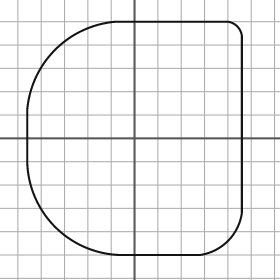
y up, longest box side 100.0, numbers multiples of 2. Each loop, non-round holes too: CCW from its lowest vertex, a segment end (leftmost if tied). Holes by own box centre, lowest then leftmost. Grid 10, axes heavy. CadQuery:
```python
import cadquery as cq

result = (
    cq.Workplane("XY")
    .moveTo(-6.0, -50.0)
    .lineTo(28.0, -50.0)
    .threePointArc((40.0, -44.0), (46.0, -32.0))
    .lineTo(46.0, 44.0)
    .threePointArc((44.0, 48.0), (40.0, 50.0))
    .lineTo(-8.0, 50.0)
    .threePointArc((-34.0, 38.0), (-46.0, 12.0))
    .lineTo(-46.0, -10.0)
    .threePointArc((-34.0, -38.0), (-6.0, -50.0))
    .close()
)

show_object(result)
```